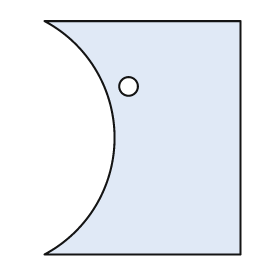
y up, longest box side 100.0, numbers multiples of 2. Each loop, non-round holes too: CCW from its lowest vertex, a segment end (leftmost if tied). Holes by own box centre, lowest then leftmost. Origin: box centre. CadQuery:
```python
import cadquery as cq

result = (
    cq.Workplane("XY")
    .moveTo(-42.0, -50.0)
    .lineTo(42.0, -50.0)
    .lineTo(42.0, 50.0)
    .lineTo(-42.0, 50.0)
    .threePointArc((-12.0, 0.0), (-42.0, -50.0))
    .close()
    .moveTo(-6.0, 22.0)
    .circle(4.0)
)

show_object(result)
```